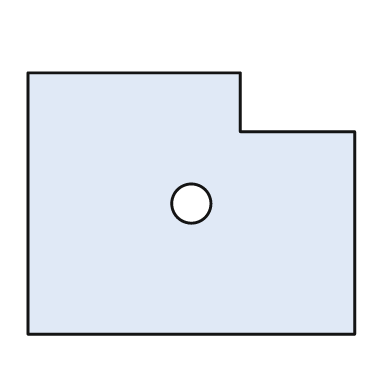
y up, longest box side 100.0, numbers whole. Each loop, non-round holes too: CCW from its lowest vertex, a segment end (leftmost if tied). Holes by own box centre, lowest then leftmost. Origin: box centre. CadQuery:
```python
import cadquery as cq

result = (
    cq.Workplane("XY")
    .moveTo(-50.0, -40.0)
    .lineTo(50.0, -40.0)
    .lineTo(50.0, 22.0)
    .lineTo(15.0, 22.0)
    .lineTo(15.0, 40.0)
    .lineTo(-50.0, 40.0)
    .close()
    .moveTo(0.0, 0.0)
    .circle(6.0)
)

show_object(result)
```